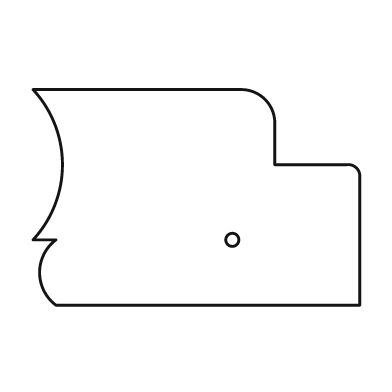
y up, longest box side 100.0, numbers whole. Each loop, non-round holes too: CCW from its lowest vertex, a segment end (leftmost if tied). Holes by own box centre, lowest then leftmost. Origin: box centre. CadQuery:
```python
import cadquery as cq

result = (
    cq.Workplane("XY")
    .moveTo(-43.0, -33.0)
    .lineTo(50.0, -33.0)
    .lineTo(50.0, 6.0)
    .threePointArc((49.0, 9.0), (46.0, 10.0))
    .lineTo(24.0, 10.0)
    .lineTo(24.0, 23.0)
    .threePointArc((21.0, 30.0), (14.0, 33.0))
    .lineTo(-50.0, 33.0)
    .threePointArc((-41.0, 10.0), (-50.0, -13.0))
    .lineTo(-43.0, -13.0)
    .threePointArc((-48.0, -23.0), (-43.0, -33.0))
    .close()
    .moveTo(11.0, -13.0)
    .circle(2.0)
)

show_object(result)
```